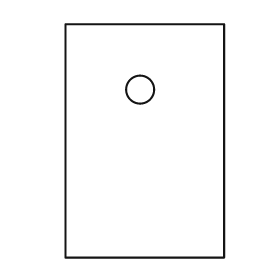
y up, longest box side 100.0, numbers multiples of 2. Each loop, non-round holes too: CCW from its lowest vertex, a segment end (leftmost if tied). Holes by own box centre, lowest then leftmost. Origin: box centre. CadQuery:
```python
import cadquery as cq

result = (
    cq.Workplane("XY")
    .moveTo(-34.0, -50.0)
    .lineTo(34.0, -50.0)
    .lineTo(34.0, 50.0)
    .lineTo(-34.0, 50.0)
    .close()
    .moveTo(-2.0, 22.0)
    .circle(6.0)
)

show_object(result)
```